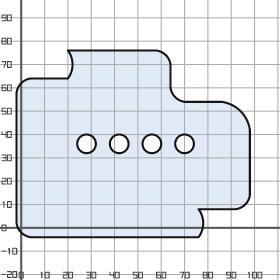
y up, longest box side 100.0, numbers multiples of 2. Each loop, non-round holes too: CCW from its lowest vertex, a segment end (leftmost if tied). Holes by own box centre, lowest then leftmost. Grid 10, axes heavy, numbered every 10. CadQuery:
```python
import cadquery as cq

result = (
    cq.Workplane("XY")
    .moveTo(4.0, -4.0)
    .lineTo(76.0, -4.0)
    .threePointArc((78.0, 2.0), (76.0, 8.0))
    .lineTo(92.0, 8.0)
    .threePointArc((96.0, 10.0), (98.0, 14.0))
    .lineTo(98.0, 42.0)
    .threePointArc((94.0, 50.0), (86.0, 54.0))
    .lineTo(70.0, 54.0)
    .threePointArc((66.0, 56.0), (64.0, 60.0))
    .lineTo(64.0, 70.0)
    .threePointArc((62.0, 74.0), (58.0, 76.0))
    .lineTo(20.0, 76.0)
    .threePointArc((22.0, 70.0), (20.0, 64.0))
    .lineTo(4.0, 64.0)
    .threePointArc((0.0, 62.0), (-2.0, 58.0))
    .lineTo(-2.0, 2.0)
    .threePointArc((0.0, -2.0), (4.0, -4.0))
    .close()
    .moveTo(28.0, 36.0)
    .circle(4.0)
    .moveTo(42.0, 36.0)
    .circle(4.0)
    .moveTo(56.0, 36.0)
    .circle(4.0)
    .moveTo(70.0, 36.0)
    .circle(4.0)
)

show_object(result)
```